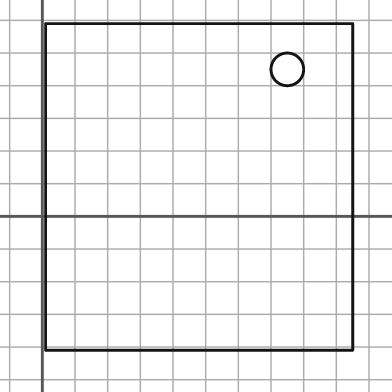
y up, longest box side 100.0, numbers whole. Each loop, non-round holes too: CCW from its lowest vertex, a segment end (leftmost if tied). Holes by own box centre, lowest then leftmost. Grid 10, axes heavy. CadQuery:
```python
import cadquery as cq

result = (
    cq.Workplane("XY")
    .moveTo(1.0, -41.0)
    .lineTo(95.0, -41.0)
    .lineTo(95.0, 59.0)
    .lineTo(1.0, 59.0)
    .close()
    .moveTo(75.0, 45.0)
    .circle(5.0)
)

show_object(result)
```